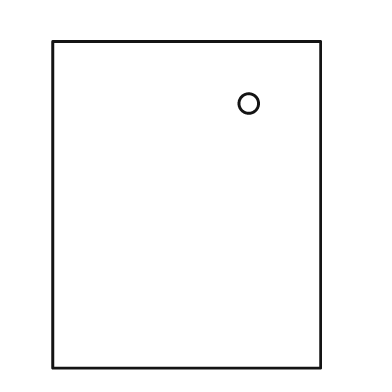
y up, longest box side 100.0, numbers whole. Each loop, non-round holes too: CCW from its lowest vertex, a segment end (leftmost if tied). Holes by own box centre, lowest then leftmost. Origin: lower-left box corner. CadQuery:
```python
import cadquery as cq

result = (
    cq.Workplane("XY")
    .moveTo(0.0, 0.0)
    .lineTo(82.0, 0.0)
    .lineTo(82.0, 100.0)
    .lineTo(0.0, 100.0)
    .close()
    .moveTo(60.0, 81.0)
    .circle(3.0)
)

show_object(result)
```